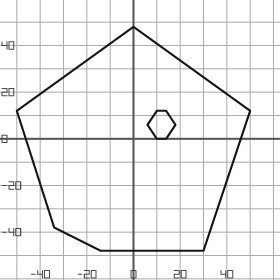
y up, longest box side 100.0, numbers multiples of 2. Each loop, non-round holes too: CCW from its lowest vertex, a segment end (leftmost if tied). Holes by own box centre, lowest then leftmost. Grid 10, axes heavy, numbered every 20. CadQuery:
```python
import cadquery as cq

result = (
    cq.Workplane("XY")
    .moveTo(-14.0, -48.0)
    .lineTo(30.0, -48.0)
    .lineTo(50.0, 12.0)
    .lineTo(0.0, 48.0)
    .lineTo(-50.0, 12.0)
    .lineTo(-34.0, -38.0)
    .close()
    .moveTo(10.0, 0.0)
    .lineTo(14.0, 0.0)
    .lineTo(18.0, 6.0)
    .lineTo(14.0, 12.0)
    .lineTo(10.0, 12.0)
    .lineTo(6.0, 6.0)
    .close()
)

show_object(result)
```